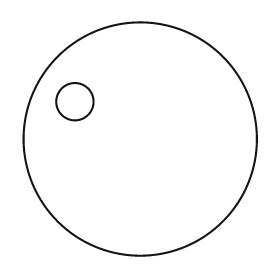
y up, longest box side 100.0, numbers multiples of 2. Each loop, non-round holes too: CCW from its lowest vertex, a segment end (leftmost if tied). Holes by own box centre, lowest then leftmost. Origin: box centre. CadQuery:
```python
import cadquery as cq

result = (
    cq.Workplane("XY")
    .moveTo(0.0, 0.0)
    .circle(50.0)
    .moveTo(-28.0, 16.0)
    .circle(8.0)
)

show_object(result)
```